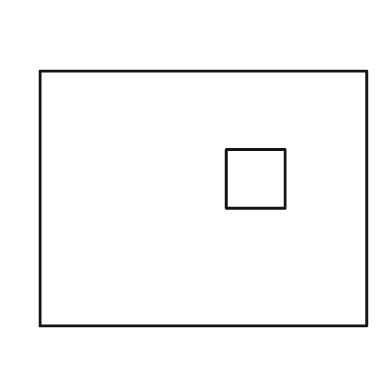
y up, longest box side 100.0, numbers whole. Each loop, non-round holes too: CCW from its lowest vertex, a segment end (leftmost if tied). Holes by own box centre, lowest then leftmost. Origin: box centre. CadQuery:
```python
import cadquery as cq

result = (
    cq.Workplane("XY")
    .moveTo(-50.0, -39.0)
    .lineTo(50.0, -39.0)
    .lineTo(50.0, 39.0)
    .lineTo(-50.0, 39.0)
    .close()
    .moveTo(7.0, -3.0)
    .lineTo(25.0, -3.0)
    .lineTo(25.0, 15.0)
    .lineTo(7.0, 15.0)
    .close()
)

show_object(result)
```